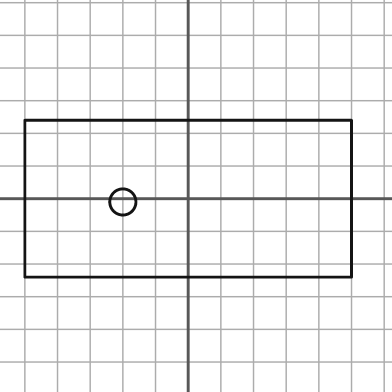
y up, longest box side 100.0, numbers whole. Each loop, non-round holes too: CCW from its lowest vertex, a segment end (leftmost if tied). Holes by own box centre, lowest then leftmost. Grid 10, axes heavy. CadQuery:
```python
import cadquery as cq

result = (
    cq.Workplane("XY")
    .moveTo(-50.0, -24.0)
    .lineTo(50.0, -24.0)
    .lineTo(50.0, 24.0)
    .lineTo(-50.0, 24.0)
    .close()
    .moveTo(-20.0, -1.0)
    .circle(4.0)
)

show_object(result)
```